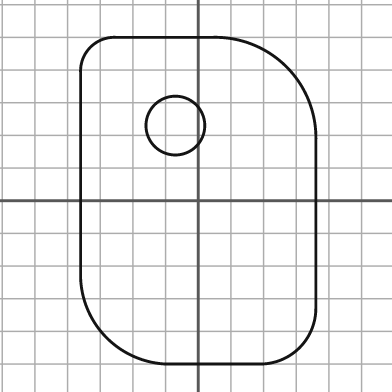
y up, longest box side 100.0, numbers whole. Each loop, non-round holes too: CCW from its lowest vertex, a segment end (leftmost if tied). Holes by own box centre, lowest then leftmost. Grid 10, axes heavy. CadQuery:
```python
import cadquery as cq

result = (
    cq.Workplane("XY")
    .moveTo(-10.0, -50.0)
    .lineTo(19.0, -50.0)
    .threePointArc((31.0, -45.0), (36.0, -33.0))
    .lineTo(36.0, 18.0)
    .threePointArc((27.0, 41.0), (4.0, 50.0))
    .lineTo(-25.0, 50.0)
    .threePointArc((-33.0, 47.0), (-36.0, 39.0))
    .lineTo(-36.0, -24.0)
    .threePointArc((-28.0, -42.0), (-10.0, -50.0))
    .close()
    .moveTo(-7.0, 23.0)
    .circle(9.0)
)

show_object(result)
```